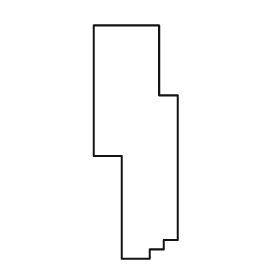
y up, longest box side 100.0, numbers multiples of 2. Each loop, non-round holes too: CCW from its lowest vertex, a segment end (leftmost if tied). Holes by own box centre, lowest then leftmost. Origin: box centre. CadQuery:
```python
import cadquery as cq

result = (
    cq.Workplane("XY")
    .moveTo(-6.0, -50.0)
    .lineTo(6.0, -50.0)
    .lineTo(6.0, -46.0)
    .lineTo(12.0, -46.0)
    .lineTo(12.0, -42.0)
    .lineTo(18.0, -42.0)
    .lineTo(18.0, 20.0)
    .lineTo(10.0, 20.0)
    .lineTo(10.0, 50.0)
    .lineTo(-18.0, 50.0)
    .lineTo(-18.0, -6.0)
    .lineTo(-6.0, -6.0)
    .close()
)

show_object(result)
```